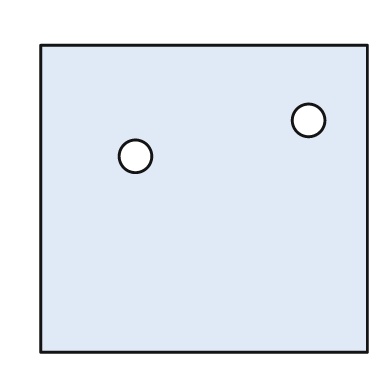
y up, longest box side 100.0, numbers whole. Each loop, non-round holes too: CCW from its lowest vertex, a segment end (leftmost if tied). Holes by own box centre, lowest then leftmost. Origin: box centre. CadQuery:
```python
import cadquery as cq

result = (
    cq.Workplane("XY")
    .moveTo(-50.0, -47.0)
    .lineTo(50.0, -47.0)
    .lineTo(50.0, 47.0)
    .lineTo(-50.0, 47.0)
    .close()
    .moveTo(-21.0, 13.0)
    .circle(5.0)
    .moveTo(32.0, 24.0)
    .circle(5.0)
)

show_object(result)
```